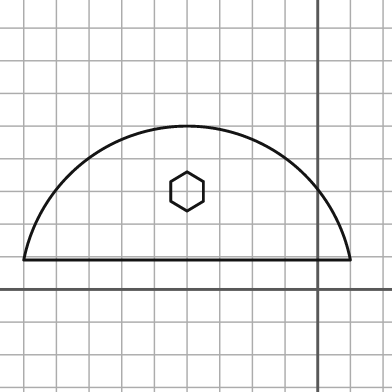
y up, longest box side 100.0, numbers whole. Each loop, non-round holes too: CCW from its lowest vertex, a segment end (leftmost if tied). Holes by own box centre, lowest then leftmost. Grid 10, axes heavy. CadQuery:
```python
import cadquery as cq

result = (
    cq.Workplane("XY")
    .moveTo(-90.0, 9.0)
    .lineTo(10.0, 9.0)
    .threePointArc((-40.0, 50.0), (-90.0, 9.0))
    .close()
    .moveTo(-40.0, 24.0)
    .lineTo(-35.0, 27.0)
    .lineTo(-35.0, 33.0)
    .lineTo(-40.0, 36.0)
    .lineTo(-45.0, 33.0)
    .lineTo(-45.0, 27.0)
    .close()
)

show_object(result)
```